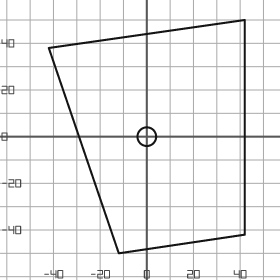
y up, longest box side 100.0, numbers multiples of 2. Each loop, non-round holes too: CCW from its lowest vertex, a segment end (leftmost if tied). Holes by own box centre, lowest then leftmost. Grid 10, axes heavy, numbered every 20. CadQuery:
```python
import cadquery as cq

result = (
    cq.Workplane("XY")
    .moveTo(-12.0, -50.0)
    .lineTo(42.0, -42.0)
    .lineTo(42.0, 50.0)
    .lineTo(-42.0, 38.0)
    .close()
    .moveTo(0.0, 0.0)
    .circle(4.0)
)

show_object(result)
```